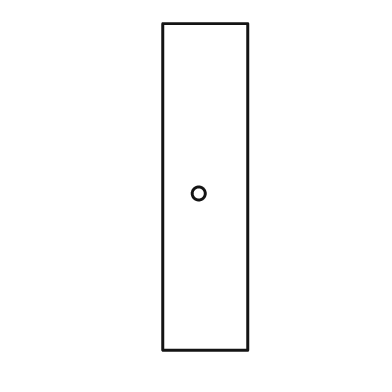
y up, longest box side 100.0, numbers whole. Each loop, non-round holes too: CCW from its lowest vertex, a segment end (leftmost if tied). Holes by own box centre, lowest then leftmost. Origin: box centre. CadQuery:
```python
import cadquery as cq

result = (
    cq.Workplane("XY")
    .moveTo(-13.0, -50.0)
    .lineTo(13.0, -50.0)
    .lineTo(13.0, 50.0)
    .lineTo(-13.0, 50.0)
    .close()
    .moveTo(-2.0, -2.0)
    .circle(2.0)
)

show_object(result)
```